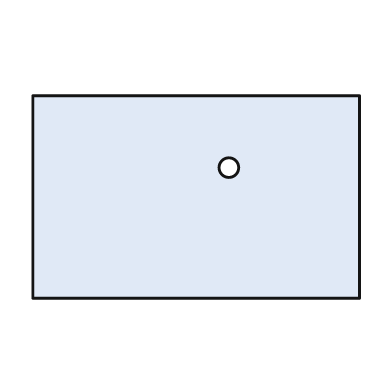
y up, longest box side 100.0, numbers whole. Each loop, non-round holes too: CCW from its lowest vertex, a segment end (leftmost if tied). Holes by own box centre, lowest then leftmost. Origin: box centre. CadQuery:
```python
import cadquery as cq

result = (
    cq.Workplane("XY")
    .moveTo(-50.0, -31.0)
    .lineTo(50.0, -31.0)
    .lineTo(50.0, 31.0)
    .lineTo(-50.0, 31.0)
    .close()
    .moveTo(10.0, 9.0)
    .circle(3.0)
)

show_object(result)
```